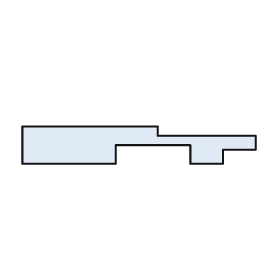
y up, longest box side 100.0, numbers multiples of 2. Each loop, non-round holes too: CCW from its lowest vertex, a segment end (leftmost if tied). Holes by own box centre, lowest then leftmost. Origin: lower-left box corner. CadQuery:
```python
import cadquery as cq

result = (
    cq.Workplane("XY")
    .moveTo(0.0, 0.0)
    .lineTo(40.0, 0.0)
    .lineTo(40.0, 8.0)
    .lineTo(72.0, 8.0)
    .lineTo(72.0, 0.0)
    .lineTo(86.0, 0.0)
    .lineTo(86.0, 6.0)
    .lineTo(100.0, 6.0)
    .lineTo(100.0, 12.0)
    .lineTo(58.0, 12.0)
    .lineTo(58.0, 16.0)
    .lineTo(0.0, 16.0)
    .close()
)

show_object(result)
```